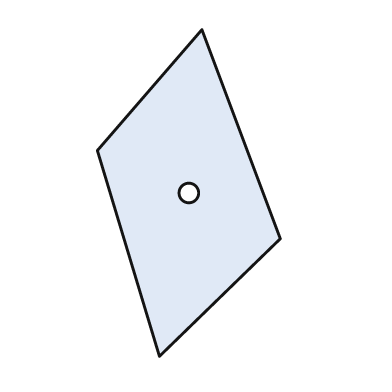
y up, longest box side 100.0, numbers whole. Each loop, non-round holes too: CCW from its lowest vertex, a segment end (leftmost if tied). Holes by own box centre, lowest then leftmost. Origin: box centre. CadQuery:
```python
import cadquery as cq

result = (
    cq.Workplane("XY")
    .moveTo(-9.0, -50.0)
    .lineTo(28.0, -14.0)
    .lineTo(4.0, 50.0)
    .lineTo(-28.0, 13.0)
    .close()
    .moveTo(0.0, 0.0)
    .circle(3.0)
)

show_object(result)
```